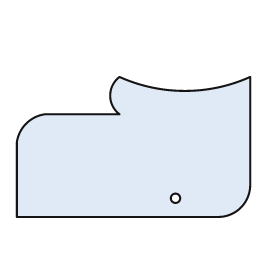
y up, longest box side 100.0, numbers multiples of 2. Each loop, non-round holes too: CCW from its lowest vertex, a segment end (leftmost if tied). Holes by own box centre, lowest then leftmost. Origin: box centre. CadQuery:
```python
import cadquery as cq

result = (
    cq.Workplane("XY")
    .moveTo(-50.0, -30.0)
    .lineTo(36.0, -30.0)
    .threePointArc((46.0, -26.0), (50.0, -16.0))
    .lineTo(50.0, 30.0)
    .threePointArc((22.0, 24.0), (-6.0, 30.0))
    .threePointArc((-10.0, 22.0), (-6.0, 14.0))
    .lineTo(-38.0, 14.0)
    .threePointArc((-46.0, 10.0), (-50.0, 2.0))
    .close()
    .moveTo(18.0, -22.0)
    .circle(2.0)
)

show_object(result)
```